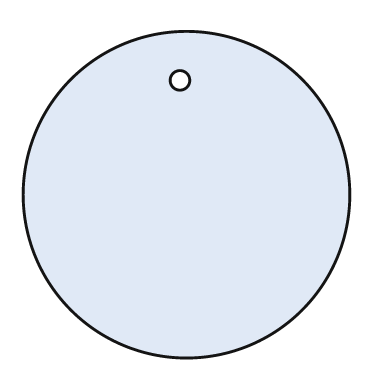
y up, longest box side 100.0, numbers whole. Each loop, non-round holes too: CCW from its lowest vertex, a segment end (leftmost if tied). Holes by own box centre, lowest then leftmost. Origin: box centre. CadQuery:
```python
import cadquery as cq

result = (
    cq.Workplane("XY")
    .moveTo(0.0, 0.0)
    .circle(50.0)
    .moveTo(-2.0, 35.0)
    .circle(3.0)
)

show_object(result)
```